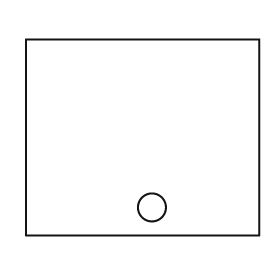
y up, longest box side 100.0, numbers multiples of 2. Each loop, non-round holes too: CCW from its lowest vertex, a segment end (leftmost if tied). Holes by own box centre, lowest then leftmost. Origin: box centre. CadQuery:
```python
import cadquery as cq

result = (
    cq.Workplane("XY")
    .moveTo(-50.0, -42.0)
    .lineTo(50.0, -42.0)
    .lineTo(50.0, 42.0)
    .lineTo(-50.0, 42.0)
    .close()
    .moveTo(4.0, -30.0)
    .circle(6.0)
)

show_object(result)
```